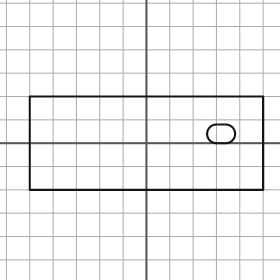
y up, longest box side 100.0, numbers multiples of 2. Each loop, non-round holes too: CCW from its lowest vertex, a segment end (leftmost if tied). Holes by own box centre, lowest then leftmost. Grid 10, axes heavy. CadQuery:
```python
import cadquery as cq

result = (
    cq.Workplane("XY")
    .moveTo(-50.0, -20.0)
    .lineTo(50.0, -20.0)
    .lineTo(50.0, 20.0)
    .lineTo(-50.0, 20.0)
    .close()
    .moveTo(30.0, 0.0)
    .lineTo(34.0, 0.0)
    .threePointArc((38.0, 4.0), (34.0, 8.0))
    .lineTo(30.0, 8.0)
    .threePointArc((26.0, 4.0), (30.0, 0.0))
    .close()
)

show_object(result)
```